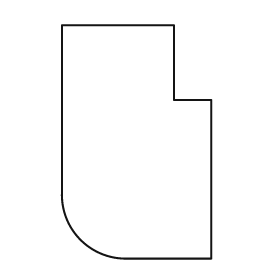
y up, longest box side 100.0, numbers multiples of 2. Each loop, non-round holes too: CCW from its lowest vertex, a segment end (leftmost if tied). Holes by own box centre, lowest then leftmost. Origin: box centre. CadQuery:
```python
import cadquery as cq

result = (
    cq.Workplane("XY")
    .moveTo(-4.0, -50.0)
    .lineTo(32.0, -50.0)
    .lineTo(32.0, 18.0)
    .lineTo(16.0, 18.0)
    .lineTo(16.0, 50.0)
    .lineTo(-32.0, 50.0)
    .lineTo(-32.0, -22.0)
    .threePointArc((-24.0, -42.0), (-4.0, -50.0))
    .close()
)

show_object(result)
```